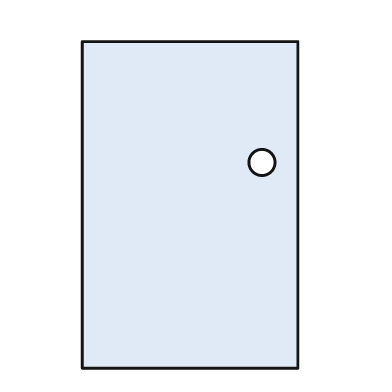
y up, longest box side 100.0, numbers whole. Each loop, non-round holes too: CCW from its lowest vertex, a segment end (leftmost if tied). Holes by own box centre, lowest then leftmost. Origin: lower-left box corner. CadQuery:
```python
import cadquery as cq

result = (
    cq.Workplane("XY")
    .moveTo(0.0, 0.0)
    .lineTo(66.0, 0.0)
    .lineTo(66.0, 100.0)
    .lineTo(0.0, 100.0)
    .close()
    .moveTo(55.0, 63.0)
    .circle(4.0)
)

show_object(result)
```